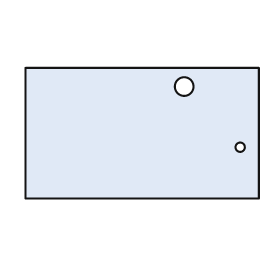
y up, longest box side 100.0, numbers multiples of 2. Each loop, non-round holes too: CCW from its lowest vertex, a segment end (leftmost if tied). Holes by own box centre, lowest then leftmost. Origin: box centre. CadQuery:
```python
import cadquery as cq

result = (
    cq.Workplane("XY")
    .moveTo(-50.0, -28.0)
    .lineTo(50.0, -28.0)
    .lineTo(50.0, 28.0)
    .lineTo(-50.0, 28.0)
    .close()
    .moveTo(42.0, -6.0)
    .circle(2.0)
    .moveTo(18.0, 20.0)
    .circle(4.0)
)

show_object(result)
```